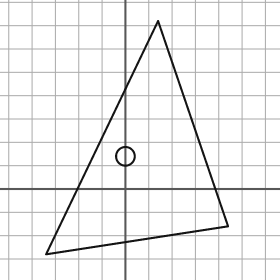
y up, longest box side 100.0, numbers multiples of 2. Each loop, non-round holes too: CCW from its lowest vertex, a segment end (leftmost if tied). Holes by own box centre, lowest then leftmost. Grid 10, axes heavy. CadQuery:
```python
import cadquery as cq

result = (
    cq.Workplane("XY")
    .moveTo(-34.0, -28.0)
    .lineTo(44.0, -16.0)
    .lineTo(14.0, 72.0)
    .close()
    .moveTo(0.0, 14.0)
    .circle(4.0)
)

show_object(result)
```